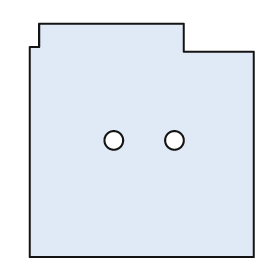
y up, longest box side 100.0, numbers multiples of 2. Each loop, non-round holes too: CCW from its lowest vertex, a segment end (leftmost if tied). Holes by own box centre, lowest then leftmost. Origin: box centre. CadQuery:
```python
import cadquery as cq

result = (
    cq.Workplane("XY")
    .moveTo(-48.0, -50.0)
    .lineTo(48.0, -50.0)
    .lineTo(48.0, 38.0)
    .lineTo(18.0, 38.0)
    .lineTo(18.0, 50.0)
    .lineTo(-44.0, 50.0)
    .lineTo(-44.0, 40.0)
    .lineTo(-48.0, 40.0)
    .close()
    .moveTo(-12.0, 0.0)
    .circle(4.0)
    .moveTo(14.0, 0.0)
    .circle(4.0)
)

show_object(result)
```